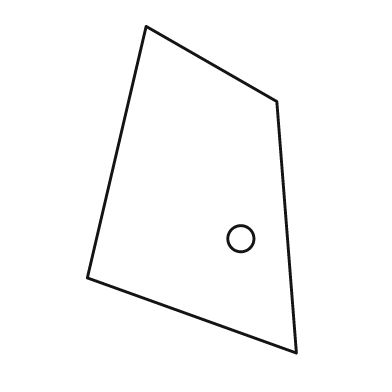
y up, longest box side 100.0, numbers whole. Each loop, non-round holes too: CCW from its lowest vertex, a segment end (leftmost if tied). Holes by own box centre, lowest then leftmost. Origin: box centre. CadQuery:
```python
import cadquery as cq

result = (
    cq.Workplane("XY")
    .moveTo(32.0, -50.0)
    .lineTo(26.0, 27.0)
    .lineTo(-14.0, 50.0)
    .lineTo(-32.0, -27.0)
    .close()
    .moveTo(15.0, -15.0)
    .circle(4.0)
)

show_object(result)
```